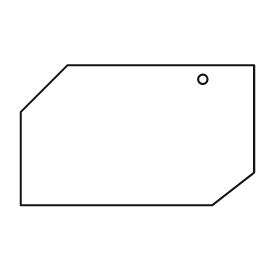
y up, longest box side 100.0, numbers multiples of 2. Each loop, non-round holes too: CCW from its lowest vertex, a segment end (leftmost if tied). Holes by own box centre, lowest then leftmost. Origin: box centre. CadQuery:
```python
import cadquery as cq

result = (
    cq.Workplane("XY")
    .moveTo(-50.0, -30.0)
    .lineTo(32.0, -30.0)
    .lineTo(50.0, -16.0)
    .lineTo(50.0, 30.0)
    .lineTo(-30.0, 30.0)
    .lineTo(-50.0, 10.0)
    .close()
    .moveTo(28.0, 24.0)
    .circle(2.0)
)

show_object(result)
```